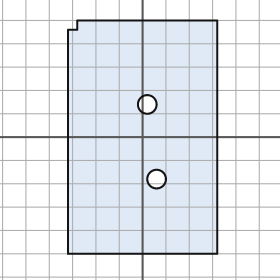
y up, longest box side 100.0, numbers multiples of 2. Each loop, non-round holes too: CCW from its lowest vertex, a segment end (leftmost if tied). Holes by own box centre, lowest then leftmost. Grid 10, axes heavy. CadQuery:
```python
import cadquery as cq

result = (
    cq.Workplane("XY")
    .moveTo(-32.0, -50.0)
    .lineTo(32.0, -50.0)
    .lineTo(32.0, 50.0)
    .lineTo(-28.0, 50.0)
    .lineTo(-28.0, 46.0)
    .lineTo(-32.0, 46.0)
    .close()
    .moveTo(6.0, -18.0)
    .circle(4.0)
    .moveTo(2.0, 14.0)
    .circle(4.0)
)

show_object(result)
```